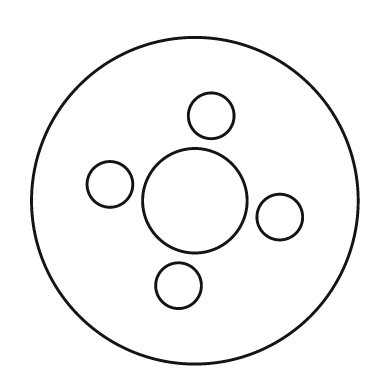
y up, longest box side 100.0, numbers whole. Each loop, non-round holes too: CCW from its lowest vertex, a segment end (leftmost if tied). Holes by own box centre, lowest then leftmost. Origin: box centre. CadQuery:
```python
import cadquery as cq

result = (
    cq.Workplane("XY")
    .moveTo(0.0, 0.0)
    .circle(50.0)
    .moveTo(-5.0, -26.0)
    .circle(7.0)
    .moveTo(26.0, -5.0)
    .circle(7.0)
    .moveTo(0.0, 0.0)
    .circle(16.0)
    .moveTo(-26.0, 5.0)
    .circle(7.0)
    .moveTo(5.0, 26.0)
    .circle(7.0)
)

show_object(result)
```